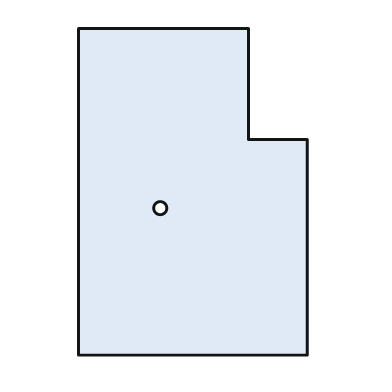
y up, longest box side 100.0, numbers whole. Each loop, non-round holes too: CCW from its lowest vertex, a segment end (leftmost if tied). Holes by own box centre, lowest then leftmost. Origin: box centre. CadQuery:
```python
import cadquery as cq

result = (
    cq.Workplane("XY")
    .moveTo(-35.0, -50.0)
    .lineTo(35.0, -50.0)
    .lineTo(35.0, 16.0)
    .lineTo(17.0, 16.0)
    .lineTo(17.0, 50.0)
    .lineTo(-35.0, 50.0)
    .close()
    .moveTo(-10.0, -5.0)
    .circle(2.0)
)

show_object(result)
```